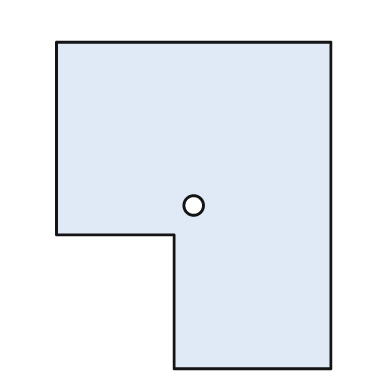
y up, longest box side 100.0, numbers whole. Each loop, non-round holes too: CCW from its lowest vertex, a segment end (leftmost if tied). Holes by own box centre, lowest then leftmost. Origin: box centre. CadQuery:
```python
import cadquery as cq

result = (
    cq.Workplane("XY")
    .moveTo(-6.0, -50.0)
    .lineTo(42.0, -50.0)
    .lineTo(42.0, 50.0)
    .lineTo(-42.0, 50.0)
    .lineTo(-42.0, -9.0)
    .lineTo(-6.0, -9.0)
    .close()
    .moveTo(0.0, 0.0)
    .circle(3.0)
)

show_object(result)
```